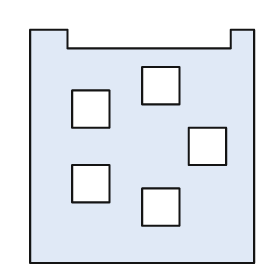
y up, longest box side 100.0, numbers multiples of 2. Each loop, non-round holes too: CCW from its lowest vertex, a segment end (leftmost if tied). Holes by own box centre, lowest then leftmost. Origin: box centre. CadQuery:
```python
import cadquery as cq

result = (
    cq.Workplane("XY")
    .moveTo(-48.0, -50.0)
    .lineTo(48.0, -50.0)
    .lineTo(48.0, 50.0)
    .lineTo(38.0, 50.0)
    .lineTo(38.0, 42.0)
    .lineTo(-32.0, 42.0)
    .lineTo(-32.0, 50.0)
    .lineTo(-48.0, 50.0)
    .close()
    .moveTo(0.0, -34.0)
    .lineTo(16.0, -34.0)
    .lineTo(16.0, -18.0)
    .lineTo(0.0, -18.0)
    .close()
    .moveTo(-30.0, -24.0)
    .lineTo(-14.0, -24.0)
    .lineTo(-14.0, -8.0)
    .lineTo(-30.0, -8.0)
    .close()
    .moveTo(20.0, -8.0)
    .lineTo(36.0, -8.0)
    .lineTo(36.0, 8.0)
    .lineTo(20.0, 8.0)
    .close()
    .moveTo(-30.0, 8.0)
    .lineTo(-14.0, 8.0)
    .lineTo(-14.0, 24.0)
    .lineTo(-30.0, 24.0)
    .close()
    .moveTo(0.0, 18.0)
    .lineTo(16.0, 18.0)
    .lineTo(16.0, 34.0)
    .lineTo(0.0, 34.0)
    .close()
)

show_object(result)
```